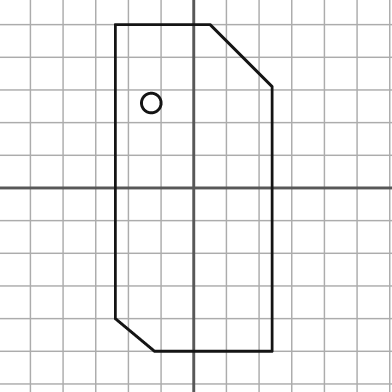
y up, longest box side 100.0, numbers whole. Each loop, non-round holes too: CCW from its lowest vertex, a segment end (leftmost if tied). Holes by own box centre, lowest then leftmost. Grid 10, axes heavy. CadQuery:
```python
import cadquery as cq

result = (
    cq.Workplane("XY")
    .moveTo(-12.0, -50.0)
    .lineTo(24.0, -50.0)
    .lineTo(24.0, 31.0)
    .lineTo(5.0, 50.0)
    .lineTo(-24.0, 50.0)
    .lineTo(-24.0, -40.0)
    .close()
    .moveTo(-13.0, 26.0)
    .circle(3.0)
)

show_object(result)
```